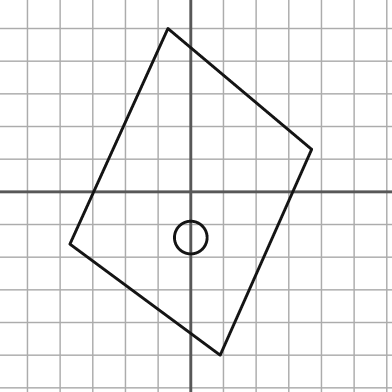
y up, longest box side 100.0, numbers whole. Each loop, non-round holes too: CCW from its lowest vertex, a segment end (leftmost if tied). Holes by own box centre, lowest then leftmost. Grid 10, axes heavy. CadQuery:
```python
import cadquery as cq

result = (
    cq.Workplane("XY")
    .moveTo(9.0, -50.0)
    .lineTo(37.0, 13.0)
    .lineTo(-7.0, 50.0)
    .lineTo(-37.0, -16.0)
    .close()
    .moveTo(0.0, -14.0)
    .circle(5.0)
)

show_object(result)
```